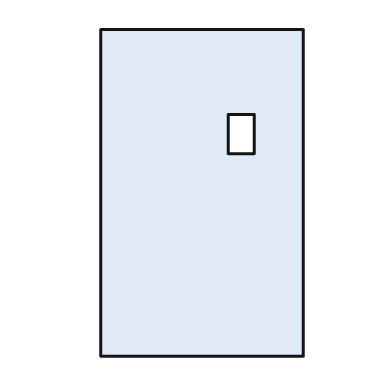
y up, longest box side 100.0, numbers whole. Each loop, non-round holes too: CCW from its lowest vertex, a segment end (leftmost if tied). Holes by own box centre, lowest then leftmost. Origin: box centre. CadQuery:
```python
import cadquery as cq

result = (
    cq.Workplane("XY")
    .moveTo(-31.0, -50.0)
    .lineTo(31.0, -50.0)
    .lineTo(31.0, 50.0)
    .lineTo(-31.0, 50.0)
    .close()
    .moveTo(8.0, 12.0)
    .lineTo(16.0, 12.0)
    .lineTo(16.0, 24.0)
    .lineTo(8.0, 24.0)
    .close()
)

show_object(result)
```